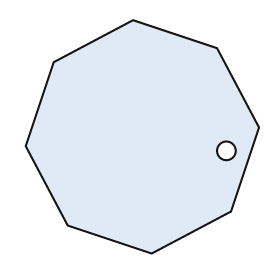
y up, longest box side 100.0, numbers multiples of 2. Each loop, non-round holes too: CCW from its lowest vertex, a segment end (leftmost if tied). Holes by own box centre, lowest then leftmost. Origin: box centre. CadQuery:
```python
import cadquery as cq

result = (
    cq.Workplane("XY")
    .moveTo(4.0, -50.0)
    .lineTo(38.0, -32.0)
    .lineTo(50.0, 4.0)
    .lineTo(32.0, 38.0)
    .lineTo(-4.0, 50.0)
    .lineTo(-38.0, 32.0)
    .lineTo(-50.0, -4.0)
    .lineTo(-32.0, -38.0)
    .close()
    .moveTo(36.0, -6.0)
    .circle(4.0)
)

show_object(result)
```